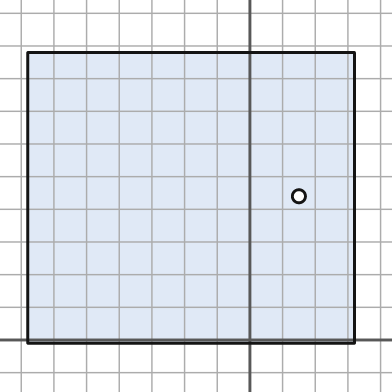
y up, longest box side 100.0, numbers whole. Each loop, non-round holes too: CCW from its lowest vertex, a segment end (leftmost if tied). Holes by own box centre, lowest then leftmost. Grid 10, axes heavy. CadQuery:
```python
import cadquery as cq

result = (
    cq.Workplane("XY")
    .moveTo(-68.0, -1.0)
    .lineTo(32.0, -1.0)
    .lineTo(32.0, 88.0)
    .lineTo(-68.0, 88.0)
    .close()
    .moveTo(15.0, 44.0)
    .circle(2.0)
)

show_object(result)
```